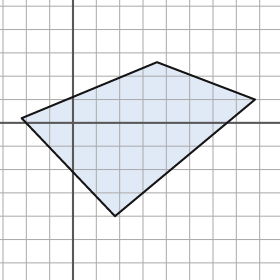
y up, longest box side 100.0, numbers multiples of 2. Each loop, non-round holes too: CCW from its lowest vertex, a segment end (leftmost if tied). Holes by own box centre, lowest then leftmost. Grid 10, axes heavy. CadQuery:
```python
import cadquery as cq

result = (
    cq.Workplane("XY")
    .moveTo(18.0, -40.0)
    .lineTo(78.0, 10.0)
    .lineTo(36.0, 26.0)
    .lineTo(-22.0, 2.0)
    .close()
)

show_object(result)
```